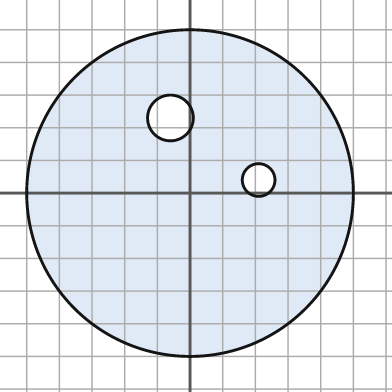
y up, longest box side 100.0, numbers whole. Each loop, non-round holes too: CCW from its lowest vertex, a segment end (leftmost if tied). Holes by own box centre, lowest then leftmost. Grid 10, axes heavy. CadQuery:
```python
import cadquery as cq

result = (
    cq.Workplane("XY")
    .moveTo(0.0, 0.0)
    .circle(50.0)
    .moveTo(21.0, 4.0)
    .circle(5.0)
    .moveTo(-6.0, 23.0)
    .circle(7.0)
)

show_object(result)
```